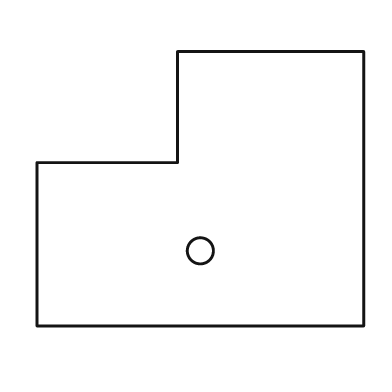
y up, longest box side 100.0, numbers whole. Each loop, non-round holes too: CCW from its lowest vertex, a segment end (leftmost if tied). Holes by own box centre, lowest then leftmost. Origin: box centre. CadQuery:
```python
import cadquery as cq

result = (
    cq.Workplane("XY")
    .moveTo(-50.0, -42.0)
    .lineTo(50.0, -42.0)
    .lineTo(50.0, 42.0)
    .lineTo(-7.0, 42.0)
    .lineTo(-7.0, 8.0)
    .lineTo(-50.0, 8.0)
    .close()
    .moveTo(0.0, -19.0)
    .circle(4.0)
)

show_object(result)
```